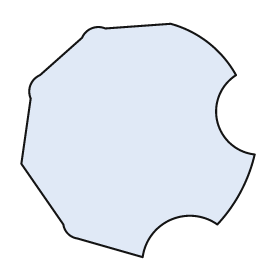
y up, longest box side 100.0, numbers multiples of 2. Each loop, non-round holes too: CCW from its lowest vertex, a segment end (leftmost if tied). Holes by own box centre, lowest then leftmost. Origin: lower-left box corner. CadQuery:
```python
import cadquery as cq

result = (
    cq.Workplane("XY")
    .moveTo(52.0, 0.0)
    .threePointArc((64.0, 16.0), (84.0, 14.0))
    .threePointArc((94.0, 28.0), (100.0, 44.0))
    .threePointArc((84.0, 58.0), (92.0, 78.0))
    .threePointArc((80.0, 92.0), (64.0, 100.0))
    .lineTo(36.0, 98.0)
    .threePointArc((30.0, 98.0), (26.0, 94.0))
    .lineTo(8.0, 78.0)
    .threePointArc((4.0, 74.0), (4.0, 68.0))
    .lineTo(0.0, 40.0)
    .lineTo(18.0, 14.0)
    .threePointArc((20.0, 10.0), (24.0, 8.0))
    .close()
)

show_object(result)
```